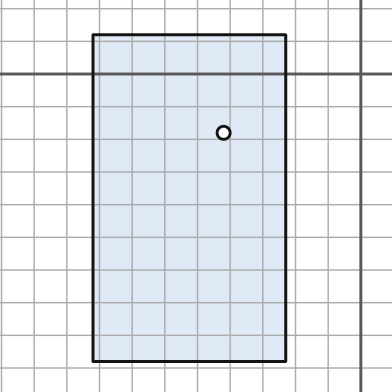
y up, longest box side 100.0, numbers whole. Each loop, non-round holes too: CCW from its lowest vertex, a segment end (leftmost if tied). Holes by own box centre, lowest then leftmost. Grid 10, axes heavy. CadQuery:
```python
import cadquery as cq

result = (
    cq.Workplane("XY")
    .moveTo(-82.0, -88.0)
    .lineTo(-23.0, -88.0)
    .lineTo(-23.0, 12.0)
    .lineTo(-82.0, 12.0)
    .close()
    .moveTo(-42.0, -18.0)
    .circle(2.0)
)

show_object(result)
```